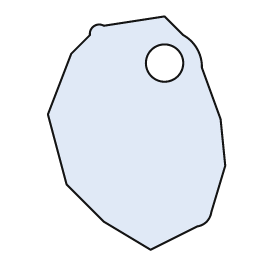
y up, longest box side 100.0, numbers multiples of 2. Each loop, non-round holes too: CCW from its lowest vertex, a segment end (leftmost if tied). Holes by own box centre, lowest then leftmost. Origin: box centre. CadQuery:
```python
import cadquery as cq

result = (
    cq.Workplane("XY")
    .moveTo(6.0, -50.0)
    .lineTo(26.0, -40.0)
    .threePointArc((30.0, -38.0), (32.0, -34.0))
    .lineTo(38.0, -14.0)
    .lineTo(36.0, 6.0)
    .lineTo(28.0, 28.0)
    .threePointArc((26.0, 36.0), (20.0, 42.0))
    .lineTo(12.0, 50.0)
    .lineTo(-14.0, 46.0)
    .threePointArc((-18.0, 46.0), (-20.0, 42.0))
    .lineTo(-28.0, 34.0)
    .lineTo(-38.0, 8.0)
    .lineTo(-30.0, -22.0)
    .lineTo(-14.0, -38.0)
    .close()
    .moveTo(12.0, 30.0)
    .circle(8.0)
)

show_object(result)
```